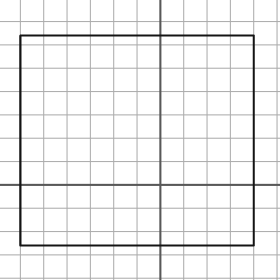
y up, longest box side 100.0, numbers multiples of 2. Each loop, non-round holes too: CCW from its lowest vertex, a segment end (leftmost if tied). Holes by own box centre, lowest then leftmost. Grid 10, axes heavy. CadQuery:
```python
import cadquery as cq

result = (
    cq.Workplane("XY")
    .moveTo(-60.0, -26.0)
    .lineTo(40.0, -26.0)
    .lineTo(40.0, 64.0)
    .lineTo(-60.0, 64.0)
    .close()
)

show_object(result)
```